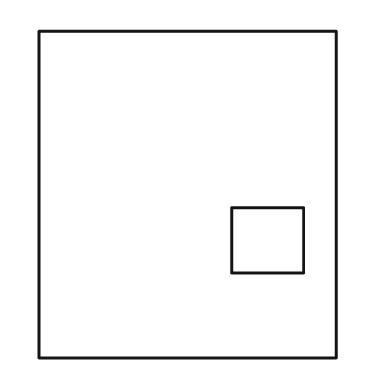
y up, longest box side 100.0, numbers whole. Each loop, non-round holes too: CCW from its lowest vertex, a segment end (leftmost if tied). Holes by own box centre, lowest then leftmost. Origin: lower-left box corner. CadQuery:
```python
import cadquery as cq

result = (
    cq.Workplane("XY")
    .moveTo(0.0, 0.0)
    .lineTo(91.0, 0.0)
    .lineTo(91.0, 100.0)
    .lineTo(0.0, 100.0)
    .close()
    .moveTo(59.0, 26.0)
    .lineTo(81.0, 26.0)
    .lineTo(81.0, 46.0)
    .lineTo(59.0, 46.0)
    .close()
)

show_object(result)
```